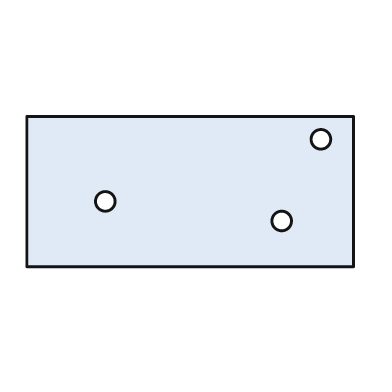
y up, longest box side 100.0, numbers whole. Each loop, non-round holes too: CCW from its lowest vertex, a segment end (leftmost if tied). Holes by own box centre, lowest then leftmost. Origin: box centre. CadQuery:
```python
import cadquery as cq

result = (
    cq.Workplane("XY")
    .moveTo(-50.0, -23.0)
    .lineTo(50.0, -23.0)
    .lineTo(50.0, 23.0)
    .lineTo(-50.0, 23.0)
    .close()
    .moveTo(28.0, -9.0)
    .circle(3.0)
    .moveTo(-26.0, -3.0)
    .circle(3.0)
    .moveTo(40.0, 16.0)
    .circle(3.0)
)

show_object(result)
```